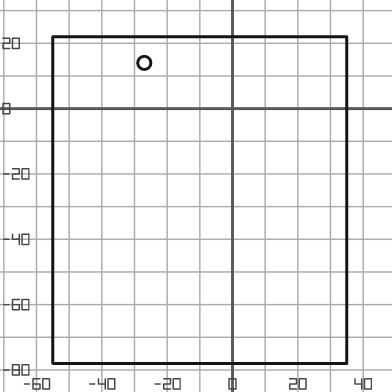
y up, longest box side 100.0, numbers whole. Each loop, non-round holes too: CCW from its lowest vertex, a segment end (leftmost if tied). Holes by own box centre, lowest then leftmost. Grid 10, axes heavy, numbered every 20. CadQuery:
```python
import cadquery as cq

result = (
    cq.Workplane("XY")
    .moveTo(-55.0, -78.0)
    .lineTo(35.0, -78.0)
    .lineTo(35.0, 22.0)
    .lineTo(-55.0, 22.0)
    .close()
    .moveTo(-27.0, 14.0)
    .circle(2.0)
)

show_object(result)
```